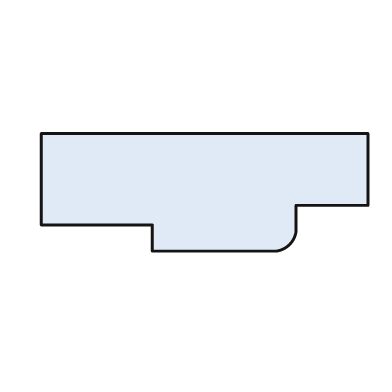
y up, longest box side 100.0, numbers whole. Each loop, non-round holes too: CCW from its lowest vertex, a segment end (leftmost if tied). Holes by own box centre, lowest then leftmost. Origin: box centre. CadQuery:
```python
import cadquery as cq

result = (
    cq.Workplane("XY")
    .moveTo(-16.0, -18.0)
    .lineTo(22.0, -18.0)
    .threePointArc((26.0, -16.0), (28.0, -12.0))
    .lineTo(28.0, -4.0)
    .lineTo(50.0, -4.0)
    .lineTo(50.0, 18.0)
    .lineTo(-50.0, 18.0)
    .lineTo(-50.0, -10.0)
    .lineTo(-16.0, -10.0)
    .close()
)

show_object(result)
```